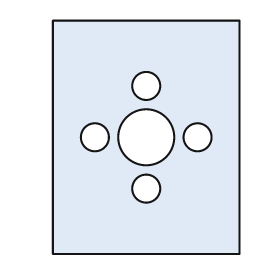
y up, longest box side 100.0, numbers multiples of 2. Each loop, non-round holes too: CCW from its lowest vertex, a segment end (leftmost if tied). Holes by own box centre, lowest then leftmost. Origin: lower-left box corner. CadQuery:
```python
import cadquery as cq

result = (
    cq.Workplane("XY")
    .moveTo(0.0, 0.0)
    .lineTo(80.0, 0.0)
    .lineTo(80.0, 100.0)
    .lineTo(0.0, 100.0)
    .close()
    .moveTo(40.0, 28.0)
    .circle(6.0)
    .moveTo(18.0, 50.0)
    .circle(6.0)
    .moveTo(40.0, 50.0)
    .circle(12.0)
    .moveTo(62.0, 50.0)
    .circle(6.0)
    .moveTo(40.0, 72.0)
    .circle(6.0)
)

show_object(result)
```